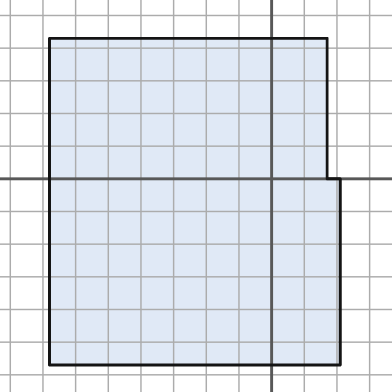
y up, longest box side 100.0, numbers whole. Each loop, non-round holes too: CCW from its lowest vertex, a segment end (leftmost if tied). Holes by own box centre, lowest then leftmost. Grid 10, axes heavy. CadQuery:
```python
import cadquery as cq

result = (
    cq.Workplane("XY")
    .moveTo(-68.0, -57.0)
    .lineTo(21.0, -57.0)
    .lineTo(21.0, 0.0)
    .lineTo(17.0, 0.0)
    .lineTo(17.0, 43.0)
    .lineTo(-68.0, 43.0)
    .close()
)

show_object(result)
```